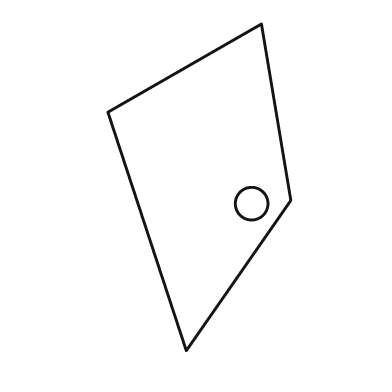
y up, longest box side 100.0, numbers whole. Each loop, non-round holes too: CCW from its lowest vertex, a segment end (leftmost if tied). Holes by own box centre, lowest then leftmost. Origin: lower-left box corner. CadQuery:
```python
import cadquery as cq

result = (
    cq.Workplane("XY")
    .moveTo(24.0, 0.0)
    .lineTo(56.0, 46.0)
    .lineTo(47.0, 100.0)
    .lineTo(0.0, 73.0)
    .close()
    .moveTo(44.0, 45.0)
    .circle(5.0)
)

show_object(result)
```